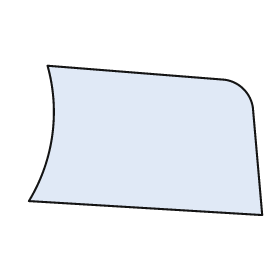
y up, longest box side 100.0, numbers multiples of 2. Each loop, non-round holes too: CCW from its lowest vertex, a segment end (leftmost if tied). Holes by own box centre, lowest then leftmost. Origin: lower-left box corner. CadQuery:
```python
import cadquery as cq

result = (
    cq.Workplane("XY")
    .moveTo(100.0, 0.0)
    .lineTo(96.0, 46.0)
    .threePointArc((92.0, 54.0), (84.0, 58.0))
    .lineTo(8.0, 64.0)
    .threePointArc((10.0, 34.0), (0.0, 6.0))
    .close()
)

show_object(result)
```